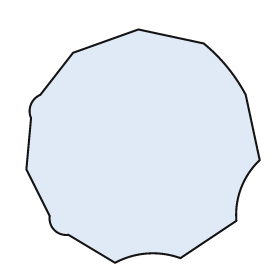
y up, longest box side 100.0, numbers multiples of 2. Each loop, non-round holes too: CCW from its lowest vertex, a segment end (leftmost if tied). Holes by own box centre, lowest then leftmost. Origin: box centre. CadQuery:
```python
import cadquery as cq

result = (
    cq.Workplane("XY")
    .moveTo(-12.0, -50.0)
    .threePointArc((2.0, -46.0), (16.0, -48.0))
    .lineTo(40.0, -32.0)
    .threePointArc((42.0, -18.0), (50.0, -6.0))
    .lineTo(44.0, 22.0)
    .threePointArc((36.0, 34.0), (26.0, 44.0))
    .lineTo(-2.0, 50.0)
    .lineTo(-30.0, 40.0)
    .lineTo(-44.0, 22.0)
    .threePointArc((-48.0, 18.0), (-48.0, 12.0))
    .lineTo(-50.0, -10.0)
    .lineTo(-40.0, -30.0)
    .threePointArc((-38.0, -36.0), (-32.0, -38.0))
    .close()
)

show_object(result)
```